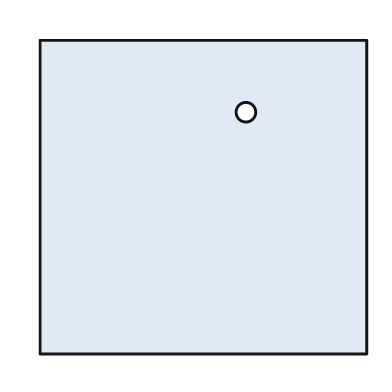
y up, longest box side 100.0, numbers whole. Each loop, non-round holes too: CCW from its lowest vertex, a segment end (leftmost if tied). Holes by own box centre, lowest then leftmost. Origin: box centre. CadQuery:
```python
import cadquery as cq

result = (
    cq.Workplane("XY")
    .moveTo(-50.0, -48.0)
    .lineTo(50.0, -48.0)
    .lineTo(50.0, 48.0)
    .lineTo(-50.0, 48.0)
    .close()
    .moveTo(13.0, 26.0)
    .circle(3.0)
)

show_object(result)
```